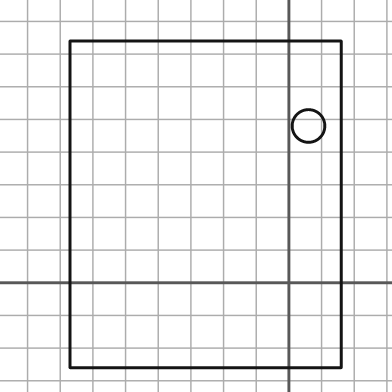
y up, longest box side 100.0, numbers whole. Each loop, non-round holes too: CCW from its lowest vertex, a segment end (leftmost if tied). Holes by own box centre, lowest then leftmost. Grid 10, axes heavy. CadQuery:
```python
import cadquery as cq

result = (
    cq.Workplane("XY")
    .moveTo(-67.0, -26.0)
    .lineTo(16.0, -26.0)
    .lineTo(16.0, 74.0)
    .lineTo(-67.0, 74.0)
    .close()
    .moveTo(6.0, 48.0)
    .circle(5.0)
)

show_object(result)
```